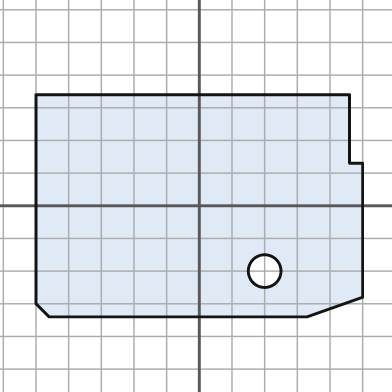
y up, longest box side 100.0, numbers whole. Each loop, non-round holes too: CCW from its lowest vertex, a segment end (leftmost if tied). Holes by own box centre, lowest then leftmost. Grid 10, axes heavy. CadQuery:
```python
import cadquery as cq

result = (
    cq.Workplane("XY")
    .moveTo(-46.0, -34.0)
    .lineTo(33.0, -34.0)
    .lineTo(50.0, -28.0)
    .lineTo(50.0, 13.0)
    .lineTo(46.0, 13.0)
    .lineTo(46.0, 34.0)
    .lineTo(-50.0, 34.0)
    .lineTo(-50.0, -30.0)
    .close()
    .moveTo(20.0, -20.0)
    .circle(5.0)
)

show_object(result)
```